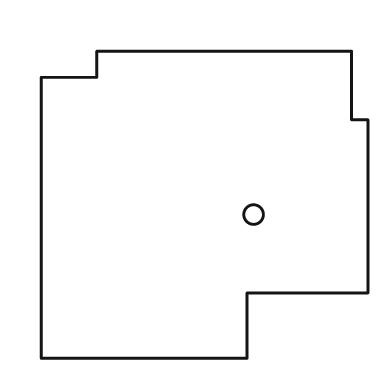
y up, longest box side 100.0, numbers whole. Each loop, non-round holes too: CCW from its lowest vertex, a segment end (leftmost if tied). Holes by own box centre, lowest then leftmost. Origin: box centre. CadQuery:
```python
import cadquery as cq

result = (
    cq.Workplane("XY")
    .moveTo(-50.0, -47.0)
    .lineTo(13.0, -47.0)
    .lineTo(13.0, -27.0)
    .lineTo(50.0, -27.0)
    .lineTo(50.0, 26.0)
    .lineTo(45.0, 26.0)
    .lineTo(45.0, 47.0)
    .lineTo(-33.0, 47.0)
    .lineTo(-33.0, 39.0)
    .lineTo(-50.0, 39.0)
    .close()
    .moveTo(15.0, -3.0)
    .circle(3.0)
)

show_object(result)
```